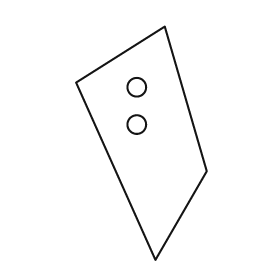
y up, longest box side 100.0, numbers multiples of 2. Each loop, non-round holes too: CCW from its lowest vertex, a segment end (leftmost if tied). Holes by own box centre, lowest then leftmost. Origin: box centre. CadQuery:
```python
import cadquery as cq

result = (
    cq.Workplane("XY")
    .moveTo(6.0, -50.0)
    .lineTo(28.0, -12.0)
    .lineTo(10.0, 50.0)
    .lineTo(-28.0, 26.0)
    .close()
    .moveTo(-2.0, 8.0)
    .circle(4.0)
    .moveTo(-2.0, 24.0)
    .circle(4.0)
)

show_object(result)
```